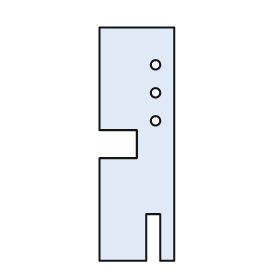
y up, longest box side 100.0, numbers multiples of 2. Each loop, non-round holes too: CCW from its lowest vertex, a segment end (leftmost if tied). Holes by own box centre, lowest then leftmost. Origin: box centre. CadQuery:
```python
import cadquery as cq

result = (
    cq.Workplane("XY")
    .moveTo(-16.0, -50.0)
    .lineTo(4.0, -50.0)
    .lineTo(4.0, -30.0)
    .lineTo(10.0, -30.0)
    .lineTo(10.0, -50.0)
    .lineTo(16.0, -50.0)
    .lineTo(16.0, 50.0)
    .lineTo(-16.0, 50.0)
    .lineTo(-16.0, 6.0)
    .lineTo(0.0, 6.0)
    .lineTo(0.0, -6.0)
    .lineTo(-16.0, -6.0)
    .close()
    .moveTo(8.0, 10.0)
    .circle(2.0)
    .moveTo(8.0, 22.0)
    .circle(2.0)
    .moveTo(8.0, 34.0)
    .circle(2.0)
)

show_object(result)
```